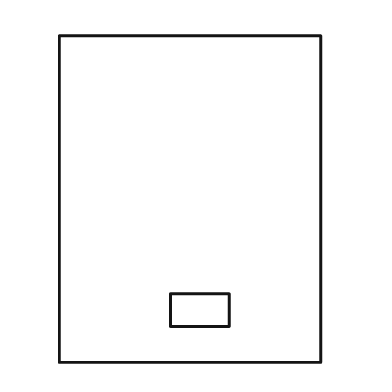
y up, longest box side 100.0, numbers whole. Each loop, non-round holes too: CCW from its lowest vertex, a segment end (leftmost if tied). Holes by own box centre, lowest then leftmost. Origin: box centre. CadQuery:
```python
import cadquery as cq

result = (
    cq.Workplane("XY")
    .moveTo(-40.0, -50.0)
    .lineTo(40.0, -50.0)
    .lineTo(40.0, 50.0)
    .lineTo(-40.0, 50.0)
    .close()
    .moveTo(-6.0, -39.0)
    .lineTo(12.0, -39.0)
    .lineTo(12.0, -29.0)
    .lineTo(-6.0, -29.0)
    .close()
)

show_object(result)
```